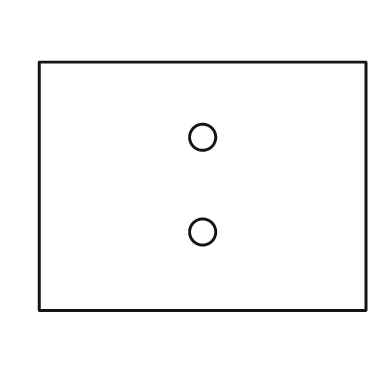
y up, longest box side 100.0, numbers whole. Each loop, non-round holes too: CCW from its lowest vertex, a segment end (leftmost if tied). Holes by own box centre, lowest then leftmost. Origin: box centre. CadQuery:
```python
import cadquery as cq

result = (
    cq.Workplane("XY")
    .moveTo(-50.0, -38.0)
    .lineTo(50.0, -38.0)
    .lineTo(50.0, 38.0)
    .lineTo(-50.0, 38.0)
    .close()
    .moveTo(0.0, -14.0)
    .circle(4.0)
    .moveTo(0.0, 15.0)
    .circle(4.0)
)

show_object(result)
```